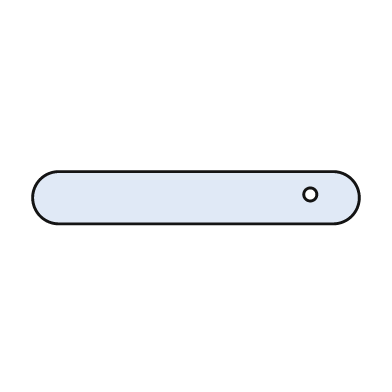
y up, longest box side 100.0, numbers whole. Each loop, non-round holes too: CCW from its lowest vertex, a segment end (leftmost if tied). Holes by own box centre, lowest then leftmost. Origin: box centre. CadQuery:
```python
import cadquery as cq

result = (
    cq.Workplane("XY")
    .moveTo(-42.0, -8.0)
    .lineTo(42.0, -8.0)
    .threePointArc((50.0, 0.0), (42.0, 8.0))
    .lineTo(-42.0, 8.0)
    .threePointArc((-50.0, 0.0), (-42.0, -8.0))
    .close()
    .moveTo(35.0, 1.0)
    .circle(2.0)
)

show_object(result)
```